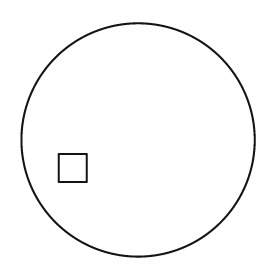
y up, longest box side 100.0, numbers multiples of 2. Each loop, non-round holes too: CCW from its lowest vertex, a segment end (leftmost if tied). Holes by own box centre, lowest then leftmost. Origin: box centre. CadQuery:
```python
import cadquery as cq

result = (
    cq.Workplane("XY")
    .moveTo(0.0, 0.0)
    .circle(50.0)
    .moveTo(-34.0, -18.0)
    .lineTo(-22.0, -18.0)
    .lineTo(-22.0, -6.0)
    .lineTo(-34.0, -6.0)
    .close()
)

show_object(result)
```